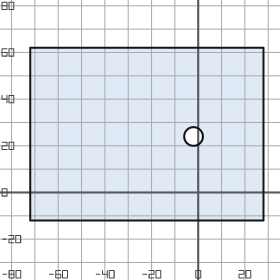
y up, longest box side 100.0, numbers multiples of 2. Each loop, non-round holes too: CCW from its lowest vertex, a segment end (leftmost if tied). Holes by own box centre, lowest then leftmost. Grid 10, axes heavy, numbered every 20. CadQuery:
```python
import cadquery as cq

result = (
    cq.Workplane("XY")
    .moveTo(-72.0, -12.0)
    .lineTo(28.0, -12.0)
    .lineTo(28.0, 62.0)
    .lineTo(-72.0, 62.0)
    .close()
    .moveTo(-2.0, 24.0)
    .circle(4.0)
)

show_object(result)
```